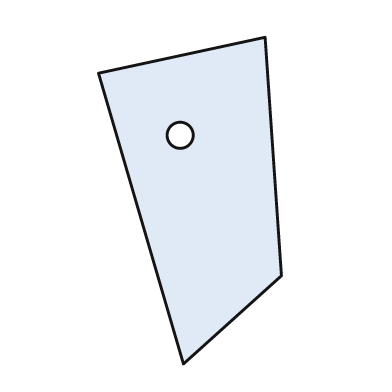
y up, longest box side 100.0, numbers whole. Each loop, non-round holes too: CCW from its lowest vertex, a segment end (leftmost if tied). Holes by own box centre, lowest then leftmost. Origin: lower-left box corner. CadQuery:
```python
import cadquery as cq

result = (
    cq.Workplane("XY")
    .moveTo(26.0, 0.0)
    .lineTo(56.0, 27.0)
    .lineTo(51.0, 100.0)
    .lineTo(0.0, 89.0)
    .close()
    .moveTo(25.0, 70.0)
    .circle(4.0)
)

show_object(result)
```